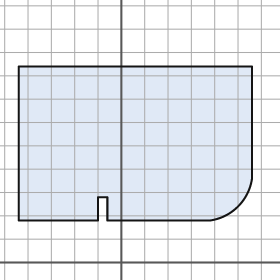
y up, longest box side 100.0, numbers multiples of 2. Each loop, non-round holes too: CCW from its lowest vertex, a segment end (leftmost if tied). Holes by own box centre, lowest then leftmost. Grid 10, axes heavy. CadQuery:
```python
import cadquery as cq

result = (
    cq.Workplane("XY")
    .moveTo(-44.0, 18.0)
    .lineTo(-10.0, 18.0)
    .lineTo(-10.0, 28.0)
    .lineTo(-6.0, 28.0)
    .lineTo(-6.0, 18.0)
    .lineTo(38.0, 18.0)
    .threePointArc((50.0, 24.0), (56.0, 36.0))
    .lineTo(56.0, 84.0)
    .lineTo(-44.0, 84.0)
    .close()
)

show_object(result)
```